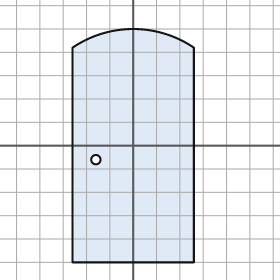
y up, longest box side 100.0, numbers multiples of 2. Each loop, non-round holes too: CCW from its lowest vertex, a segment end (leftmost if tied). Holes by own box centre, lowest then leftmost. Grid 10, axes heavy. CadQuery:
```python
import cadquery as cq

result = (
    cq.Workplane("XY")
    .moveTo(-26.0, -50.0)
    .lineTo(26.0, -50.0)
    .lineTo(26.0, 42.0)
    .threePointArc((0.0, 50.0), (-26.0, 42.0))
    .close()
    .moveTo(-16.0, -6.0)
    .circle(2.0)
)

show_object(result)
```